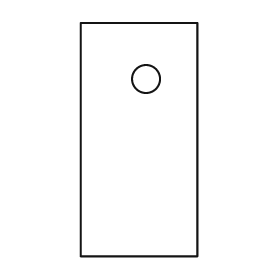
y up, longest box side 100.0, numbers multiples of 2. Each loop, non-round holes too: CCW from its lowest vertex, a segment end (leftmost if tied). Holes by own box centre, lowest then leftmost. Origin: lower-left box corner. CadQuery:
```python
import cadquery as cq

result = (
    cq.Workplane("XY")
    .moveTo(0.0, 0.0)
    .lineTo(50.0, 0.0)
    .lineTo(50.0, 100.0)
    .lineTo(0.0, 100.0)
    .close()
    .moveTo(28.0, 76.0)
    .circle(6.0)
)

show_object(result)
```